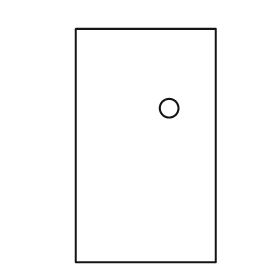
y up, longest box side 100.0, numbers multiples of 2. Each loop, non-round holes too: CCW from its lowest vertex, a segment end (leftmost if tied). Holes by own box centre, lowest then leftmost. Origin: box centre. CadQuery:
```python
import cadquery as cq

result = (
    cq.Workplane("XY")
    .moveTo(-30.0, -50.0)
    .lineTo(30.0, -50.0)
    .lineTo(30.0, 50.0)
    .lineTo(-30.0, 50.0)
    .close()
    .moveTo(10.0, 16.0)
    .circle(4.0)
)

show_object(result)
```